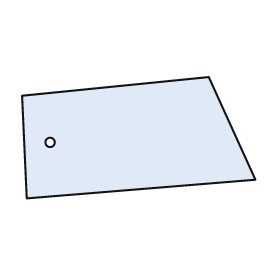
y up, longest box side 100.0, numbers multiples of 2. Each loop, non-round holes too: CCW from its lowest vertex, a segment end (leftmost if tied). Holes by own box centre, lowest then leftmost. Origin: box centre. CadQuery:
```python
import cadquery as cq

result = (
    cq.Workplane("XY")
    .moveTo(-48.0, -26.0)
    .lineTo(50.0, -18.0)
    .lineTo(30.0, 26.0)
    .lineTo(-50.0, 18.0)
    .close()
    .moveTo(-38.0, -2.0)
    .circle(2.0)
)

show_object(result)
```